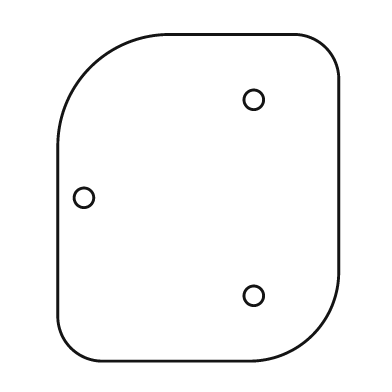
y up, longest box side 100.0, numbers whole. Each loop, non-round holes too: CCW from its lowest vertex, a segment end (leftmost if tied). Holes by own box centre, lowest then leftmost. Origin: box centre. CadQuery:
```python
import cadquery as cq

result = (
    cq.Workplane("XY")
    .moveTo(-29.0, -50.0)
    .lineTo(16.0, -50.0)
    .threePointArc((35.0, -42.0), (43.0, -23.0))
    .lineTo(43.0, 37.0)
    .threePointArc((39.0, 46.0), (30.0, 50.0))
    .lineTo(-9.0, 50.0)
    .threePointArc((-33.0, 40.0), (-43.0, 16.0))
    .lineTo(-43.0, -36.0)
    .threePointArc((-39.0, -46.0), (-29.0, -50.0))
    .close()
    .moveTo(17.0, -30.0)
    .circle(3.0)
    .moveTo(-35.0, 0.0)
    .circle(3.0)
    .moveTo(17.0, 30.0)
    .circle(3.0)
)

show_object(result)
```